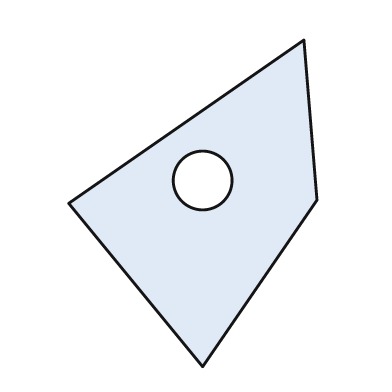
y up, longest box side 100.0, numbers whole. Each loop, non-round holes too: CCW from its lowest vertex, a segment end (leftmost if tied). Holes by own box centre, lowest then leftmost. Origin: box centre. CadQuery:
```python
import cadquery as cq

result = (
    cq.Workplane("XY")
    .moveTo(3.0, -50.0)
    .lineTo(38.0, 1.0)
    .lineTo(34.0, 50.0)
    .lineTo(-38.0, 0.0)
    .close()
    .moveTo(3.0, 7.0)
    .circle(9.0)
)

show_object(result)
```